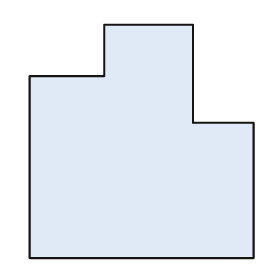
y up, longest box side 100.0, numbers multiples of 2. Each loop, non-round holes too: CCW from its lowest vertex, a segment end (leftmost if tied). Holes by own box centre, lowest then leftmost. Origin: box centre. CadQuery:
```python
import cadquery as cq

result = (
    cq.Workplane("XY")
    .moveTo(-48.0, -50.0)
    .lineTo(48.0, -50.0)
    .lineTo(48.0, 8.0)
    .lineTo(22.0, 8.0)
    .lineTo(22.0, 50.0)
    .lineTo(-16.0, 50.0)
    .lineTo(-16.0, 28.0)
    .lineTo(-48.0, 28.0)
    .close()
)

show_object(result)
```